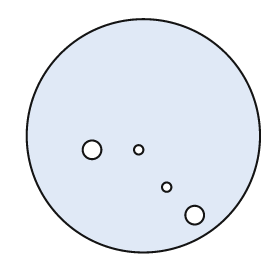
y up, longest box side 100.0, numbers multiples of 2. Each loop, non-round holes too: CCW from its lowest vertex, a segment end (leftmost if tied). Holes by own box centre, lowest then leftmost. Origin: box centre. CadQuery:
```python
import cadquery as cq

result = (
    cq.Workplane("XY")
    .moveTo(0.0, 0.0)
    .circle(50.0)
    .moveTo(22.0, -34.0)
    .circle(4.0)
    .moveTo(10.0, -22.0)
    .circle(2.0)
    .moveTo(-22.0, -6.0)
    .circle(4.0)
    .moveTo(-2.0, -6.0)
    .circle(2.0)
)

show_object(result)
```